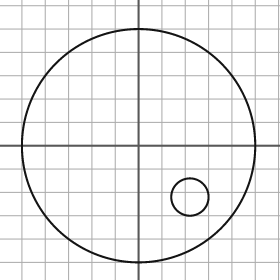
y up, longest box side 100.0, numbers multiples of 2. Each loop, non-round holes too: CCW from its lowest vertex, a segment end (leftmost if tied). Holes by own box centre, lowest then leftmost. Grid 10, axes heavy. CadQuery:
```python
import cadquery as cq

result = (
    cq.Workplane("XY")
    .moveTo(0.0, 0.0)
    .circle(50.0)
    .moveTo(22.0, -22.0)
    .circle(8.0)
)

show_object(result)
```